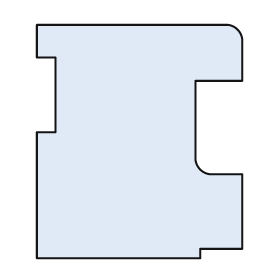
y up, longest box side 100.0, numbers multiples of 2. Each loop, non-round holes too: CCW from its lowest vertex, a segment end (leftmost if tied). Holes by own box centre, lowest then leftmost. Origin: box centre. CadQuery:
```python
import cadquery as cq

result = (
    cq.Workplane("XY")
    .moveTo(-44.0, -50.0)
    .lineTo(26.0, -50.0)
    .lineTo(26.0, -46.0)
    .lineTo(44.0, -46.0)
    .lineTo(44.0, -14.0)
    .lineTo(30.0, -14.0)
    .threePointArc((26.0, -12.0), (24.0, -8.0))
    .lineTo(24.0, 26.0)
    .lineTo(44.0, 26.0)
    .lineTo(44.0, 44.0)
    .threePointArc((42.0, 48.0), (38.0, 50.0))
    .lineTo(-44.0, 50.0)
    .lineTo(-44.0, 36.0)
    .lineTo(-36.0, 36.0)
    .lineTo(-36.0, 4.0)
    .lineTo(-44.0, 4.0)
    .close()
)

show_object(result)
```